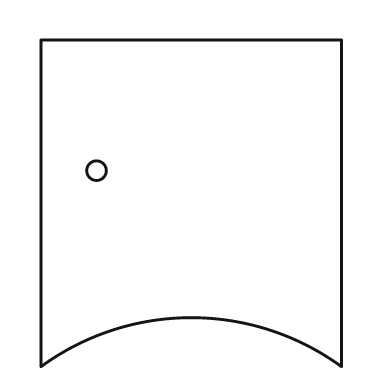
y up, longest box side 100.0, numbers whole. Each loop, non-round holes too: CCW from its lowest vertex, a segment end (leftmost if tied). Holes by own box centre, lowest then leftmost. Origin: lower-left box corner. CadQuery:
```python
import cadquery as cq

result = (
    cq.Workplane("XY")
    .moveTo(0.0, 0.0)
    .threePointArc((46.0, 15.0), (92.0, 0.0))
    .lineTo(92.0, 100.0)
    .lineTo(0.0, 100.0)
    .close()
    .moveTo(17.0, 60.0)
    .circle(3.0)
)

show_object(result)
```